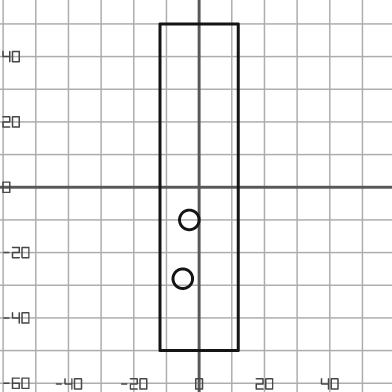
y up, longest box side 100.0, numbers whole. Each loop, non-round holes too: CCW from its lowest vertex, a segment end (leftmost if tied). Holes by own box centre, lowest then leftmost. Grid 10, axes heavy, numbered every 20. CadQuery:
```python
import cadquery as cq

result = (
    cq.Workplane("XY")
    .moveTo(-12.0, -50.0)
    .lineTo(12.0, -50.0)
    .lineTo(12.0, 50.0)
    .lineTo(-12.0, 50.0)
    .close()
    .moveTo(-5.0, -28.0)
    .circle(3.0)
    .moveTo(-3.0, -10.0)
    .circle(3.0)
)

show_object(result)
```